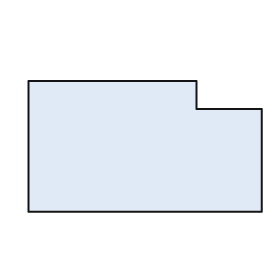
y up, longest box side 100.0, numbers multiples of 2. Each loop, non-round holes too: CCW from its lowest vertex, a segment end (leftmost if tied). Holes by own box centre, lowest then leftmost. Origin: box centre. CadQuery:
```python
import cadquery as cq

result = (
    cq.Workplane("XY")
    .moveTo(-50.0, -28.0)
    .lineTo(50.0, -28.0)
    .lineTo(50.0, 16.0)
    .lineTo(22.0, 16.0)
    .lineTo(22.0, 28.0)
    .lineTo(-50.0, 28.0)
    .close()
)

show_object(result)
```